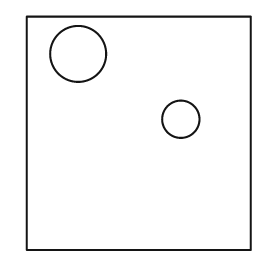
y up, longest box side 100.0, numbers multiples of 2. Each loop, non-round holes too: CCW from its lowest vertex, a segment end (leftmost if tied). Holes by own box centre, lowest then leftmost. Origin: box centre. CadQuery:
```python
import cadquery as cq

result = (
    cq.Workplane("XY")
    .moveTo(-48.0, -50.0)
    .lineTo(48.0, -50.0)
    .lineTo(48.0, 50.0)
    .lineTo(-48.0, 50.0)
    .close()
    .moveTo(18.0, 6.0)
    .circle(8.0)
    .moveTo(-26.0, 34.0)
    .circle(12.0)
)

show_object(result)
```